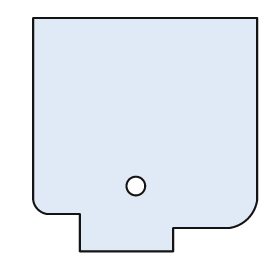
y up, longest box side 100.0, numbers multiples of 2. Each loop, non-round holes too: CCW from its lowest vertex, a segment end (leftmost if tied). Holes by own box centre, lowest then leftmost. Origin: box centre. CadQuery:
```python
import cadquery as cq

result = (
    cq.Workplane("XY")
    .moveTo(-28.0, -50.0)
    .lineTo(12.0, -50.0)
    .lineTo(12.0, -40.0)
    .lineTo(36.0, -40.0)
    .threePointArc((44.0, -36.0), (48.0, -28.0))
    .lineTo(48.0, 50.0)
    .lineTo(-48.0, 50.0)
    .lineTo(-48.0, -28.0)
    .threePointArc((-46.0, -32.0), (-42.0, -34.0))
    .lineTo(-28.0, -34.0)
    .close()
    .moveTo(-4.0, -22.0)
    .circle(4.0)
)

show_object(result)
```